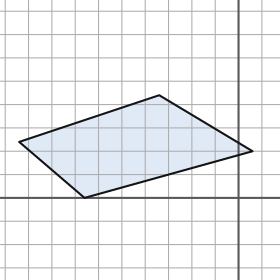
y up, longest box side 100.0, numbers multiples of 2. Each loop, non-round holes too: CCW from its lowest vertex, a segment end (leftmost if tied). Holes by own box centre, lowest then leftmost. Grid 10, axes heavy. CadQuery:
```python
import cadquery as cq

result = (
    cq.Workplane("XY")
    .moveTo(-66.0, 0.0)
    .lineTo(6.0, 20.0)
    .lineTo(-34.0, 44.0)
    .lineTo(-94.0, 24.0)
    .close()
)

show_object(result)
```